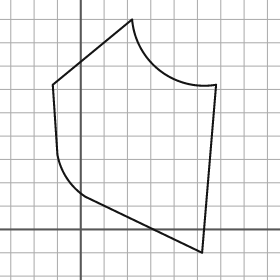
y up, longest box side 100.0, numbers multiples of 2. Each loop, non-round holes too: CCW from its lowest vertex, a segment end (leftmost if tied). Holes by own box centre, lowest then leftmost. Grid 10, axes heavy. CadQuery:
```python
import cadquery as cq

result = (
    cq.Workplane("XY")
    .moveTo(52.0, -10.0)
    .lineTo(58.0, 62.0)
    .threePointArc((34.0, 68.0), (22.0, 90.0))
    .lineTo(-12.0, 62.0)
    .lineTo(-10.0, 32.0)
    .threePointArc((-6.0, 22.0), (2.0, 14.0))
    .close()
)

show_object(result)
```